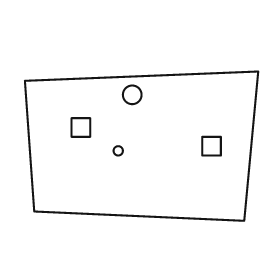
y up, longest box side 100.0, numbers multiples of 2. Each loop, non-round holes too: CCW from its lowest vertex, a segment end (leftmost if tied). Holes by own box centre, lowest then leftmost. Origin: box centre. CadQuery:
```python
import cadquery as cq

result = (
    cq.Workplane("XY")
    .moveTo(44.0, -32.0)
    .lineTo(50.0, 32.0)
    .lineTo(-50.0, 28.0)
    .lineTo(-46.0, -28.0)
    .close()
    .moveTo(-10.0, -2.0)
    .circle(2.0)
    .moveTo(26.0, -4.0)
    .lineTo(34.0, -4.0)
    .lineTo(34.0, 4.0)
    .lineTo(26.0, 4.0)
    .close()
    .moveTo(-30.0, 4.0)
    .lineTo(-22.0, 4.0)
    .lineTo(-22.0, 12.0)
    .lineTo(-30.0, 12.0)
    .close()
    .moveTo(-4.0, 22.0)
    .circle(4.0)
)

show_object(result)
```